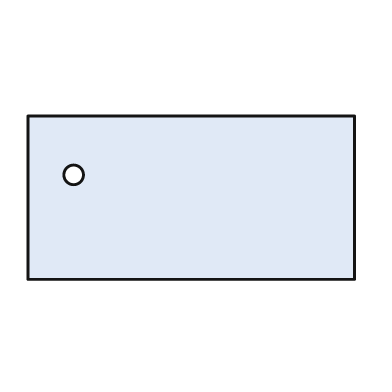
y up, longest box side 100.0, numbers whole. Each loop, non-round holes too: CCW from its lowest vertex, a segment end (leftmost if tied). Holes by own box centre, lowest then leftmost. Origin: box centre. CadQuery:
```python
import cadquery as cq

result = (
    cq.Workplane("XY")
    .moveTo(-50.0, -25.0)
    .lineTo(50.0, -25.0)
    .lineTo(50.0, 25.0)
    .lineTo(-50.0, 25.0)
    .close()
    .moveTo(-36.0, 7.0)
    .circle(3.0)
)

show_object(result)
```